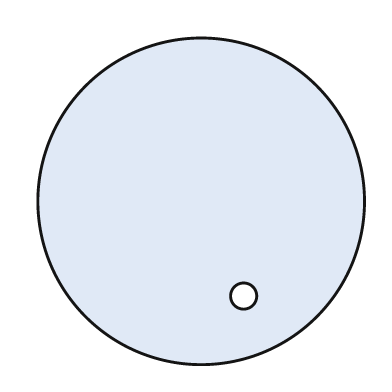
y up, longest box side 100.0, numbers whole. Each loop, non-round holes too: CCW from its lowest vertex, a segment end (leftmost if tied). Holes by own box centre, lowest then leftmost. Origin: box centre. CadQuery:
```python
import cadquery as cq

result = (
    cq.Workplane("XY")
    .moveTo(0.0, 0.0)
    .circle(50.0)
    .moveTo(13.0, -29.0)
    .circle(4.0)
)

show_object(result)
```